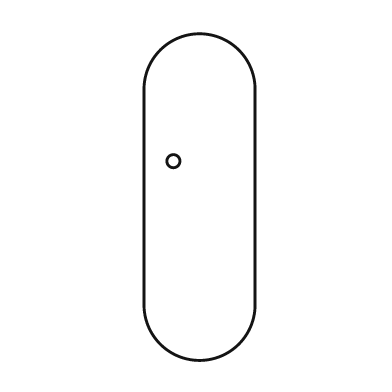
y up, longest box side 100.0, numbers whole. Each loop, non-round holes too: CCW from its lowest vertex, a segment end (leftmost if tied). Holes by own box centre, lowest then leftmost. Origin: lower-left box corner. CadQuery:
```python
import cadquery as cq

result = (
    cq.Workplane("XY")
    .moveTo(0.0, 17.0)
    .threePointArc((17.0, 0.0), (34.0, 17.0))
    .lineTo(34.0, 83.0)
    .threePointArc((17.0, 100.0), (0.0, 83.0))
    .close()
    .moveTo(9.0, 61.0)
    .circle(2.0)
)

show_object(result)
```